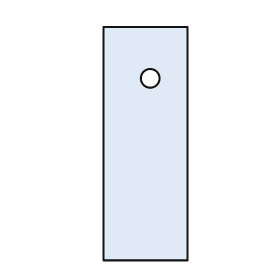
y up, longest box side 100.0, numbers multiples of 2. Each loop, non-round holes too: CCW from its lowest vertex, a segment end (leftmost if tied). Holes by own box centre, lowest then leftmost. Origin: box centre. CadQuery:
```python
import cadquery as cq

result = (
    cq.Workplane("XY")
    .moveTo(-18.0, -50.0)
    .lineTo(18.0, -50.0)
    .lineTo(18.0, 50.0)
    .lineTo(-18.0, 50.0)
    .close()
    .moveTo(2.0, 28.0)
    .circle(4.0)
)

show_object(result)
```